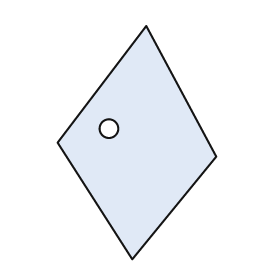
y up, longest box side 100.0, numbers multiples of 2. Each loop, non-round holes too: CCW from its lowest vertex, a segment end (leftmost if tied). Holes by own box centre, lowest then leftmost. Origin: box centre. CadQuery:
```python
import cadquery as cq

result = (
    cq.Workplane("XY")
    .moveTo(-2.0, -50.0)
    .lineTo(34.0, -6.0)
    .lineTo(4.0, 50.0)
    .lineTo(-34.0, 0.0)
    .close()
    .moveTo(-12.0, 6.0)
    .circle(4.0)
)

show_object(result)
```